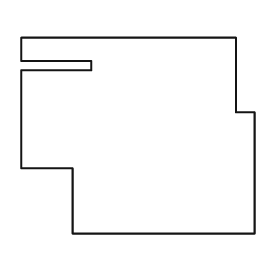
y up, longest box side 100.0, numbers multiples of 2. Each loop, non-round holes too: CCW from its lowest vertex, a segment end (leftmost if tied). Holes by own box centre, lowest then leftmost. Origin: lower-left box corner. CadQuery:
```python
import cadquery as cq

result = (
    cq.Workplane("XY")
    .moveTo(22.0, 0.0)
    .lineTo(100.0, 0.0)
    .lineTo(100.0, 52.0)
    .lineTo(92.0, 52.0)
    .lineTo(92.0, 84.0)
    .lineTo(0.0, 84.0)
    .lineTo(0.0, 74.0)
    .lineTo(30.0, 74.0)
    .lineTo(30.0, 70.0)
    .lineTo(0.0, 70.0)
    .lineTo(0.0, 28.0)
    .lineTo(22.0, 28.0)
    .close()
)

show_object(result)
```